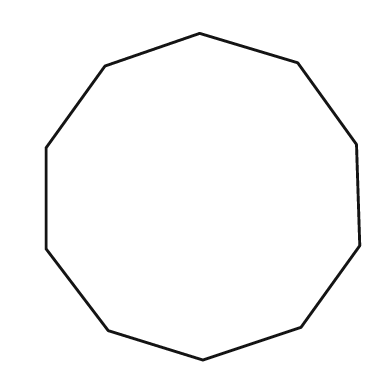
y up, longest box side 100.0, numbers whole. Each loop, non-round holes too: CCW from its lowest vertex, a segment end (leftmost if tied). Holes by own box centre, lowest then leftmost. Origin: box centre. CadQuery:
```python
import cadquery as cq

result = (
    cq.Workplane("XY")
    .moveTo(0.0, -50.0)
    .lineTo(30.0, -40.0)
    .lineTo(48.0, -15.0)
    .lineTo(47.0, 16.0)
    .lineTo(29.0, 41.0)
    .lineTo(-1.0, 50.0)
    .lineTo(-30.0, 40.0)
    .lineTo(-48.0, 15.0)
    .lineTo(-48.0, -16.0)
    .lineTo(-29.0, -41.0)
    .close()
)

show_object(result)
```